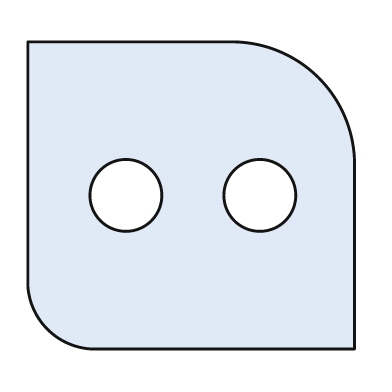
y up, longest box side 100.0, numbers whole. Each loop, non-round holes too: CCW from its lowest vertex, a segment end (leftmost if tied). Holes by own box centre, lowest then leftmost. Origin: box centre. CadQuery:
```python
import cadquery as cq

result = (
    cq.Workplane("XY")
    .moveTo(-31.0, -47.0)
    .lineTo(50.0, -47.0)
    .lineTo(50.0, 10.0)
    .threePointArc((39.0, 36.0), (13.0, 47.0))
    .lineTo(-50.0, 47.0)
    .lineTo(-50.0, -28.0)
    .threePointArc((-44.0, -41.0), (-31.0, -47.0))
    .close()
    .moveTo(-20.0, 0.0)
    .circle(11.0)
    .moveTo(21.0, 0.0)
    .circle(11.0)
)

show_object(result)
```